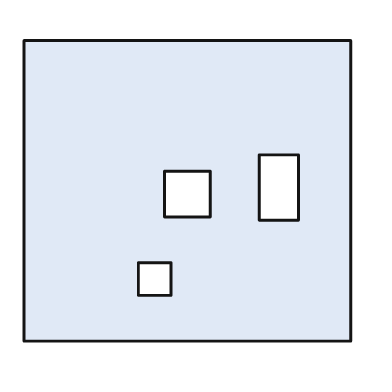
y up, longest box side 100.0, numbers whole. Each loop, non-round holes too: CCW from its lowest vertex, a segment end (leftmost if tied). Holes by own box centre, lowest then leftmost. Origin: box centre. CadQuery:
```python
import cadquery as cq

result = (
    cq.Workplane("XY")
    .moveTo(-50.0, -46.0)
    .lineTo(50.0, -46.0)
    .lineTo(50.0, 46.0)
    .lineTo(-50.0, 46.0)
    .close()
    .moveTo(-15.0, -32.0)
    .lineTo(-5.0, -32.0)
    .lineTo(-5.0, -22.0)
    .lineTo(-15.0, -22.0)
    .close()
    .moveTo(-7.0, -8.0)
    .lineTo(7.0, -8.0)
    .lineTo(7.0, 6.0)
    .lineTo(-7.0, 6.0)
    .close()
    .moveTo(22.0, -9.0)
    .lineTo(34.0, -9.0)
    .lineTo(34.0, 11.0)
    .lineTo(22.0, 11.0)
    .close()
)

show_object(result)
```